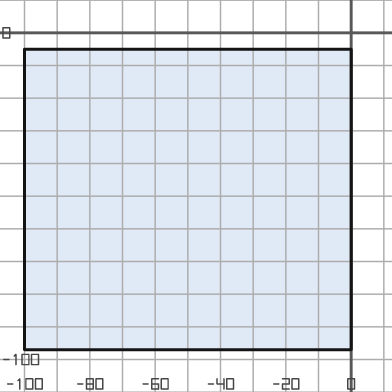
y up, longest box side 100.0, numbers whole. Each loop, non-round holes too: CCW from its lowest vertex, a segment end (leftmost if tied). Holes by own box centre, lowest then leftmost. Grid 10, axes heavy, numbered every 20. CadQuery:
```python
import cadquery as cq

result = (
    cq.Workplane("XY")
    .moveTo(-100.0, -97.0)
    .lineTo(0.0, -97.0)
    .lineTo(0.0, -5.0)
    .lineTo(-100.0, -5.0)
    .close()
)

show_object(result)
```